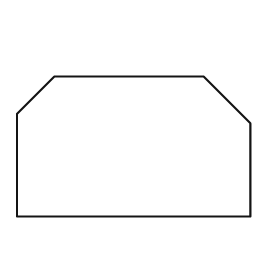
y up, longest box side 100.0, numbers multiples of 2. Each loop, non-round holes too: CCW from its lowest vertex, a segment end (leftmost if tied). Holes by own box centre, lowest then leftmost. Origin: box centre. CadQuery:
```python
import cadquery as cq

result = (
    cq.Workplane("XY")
    .moveTo(-50.0, -30.0)
    .lineTo(50.0, -30.0)
    .lineTo(50.0, 10.0)
    .lineTo(30.0, 30.0)
    .lineTo(-34.0, 30.0)
    .lineTo(-50.0, 14.0)
    .close()
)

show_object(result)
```